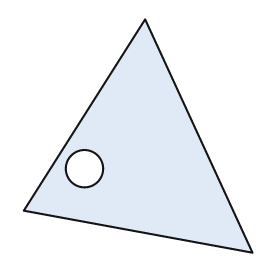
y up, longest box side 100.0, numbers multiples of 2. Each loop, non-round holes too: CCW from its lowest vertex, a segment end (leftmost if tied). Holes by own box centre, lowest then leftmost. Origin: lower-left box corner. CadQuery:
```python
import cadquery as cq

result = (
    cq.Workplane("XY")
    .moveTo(98.0, 0.0)
    .lineTo(52.0, 100.0)
    .lineTo(0.0, 18.0)
    .close()
    .moveTo(26.0, 36.0)
    .circle(8.0)
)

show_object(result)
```